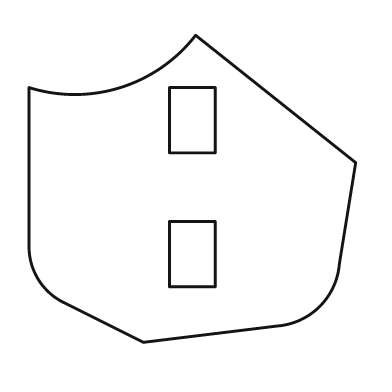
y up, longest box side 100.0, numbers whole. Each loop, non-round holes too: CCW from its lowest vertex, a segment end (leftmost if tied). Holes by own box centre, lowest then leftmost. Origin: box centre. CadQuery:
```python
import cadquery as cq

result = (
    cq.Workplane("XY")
    .moveTo(-15.0, -47.0)
    .lineTo(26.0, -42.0)
    .threePointArc((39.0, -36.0), (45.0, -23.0))
    .lineTo(50.0, 8.0)
    .lineTo(1.0, 47.0)
    .threePointArc((-22.0, 31.0), (-50.0, 31.0))
    .lineTo(-50.0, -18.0)
    .threePointArc((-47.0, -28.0), (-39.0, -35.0))
    .close()
    .moveTo(-7.0, -30.0)
    .lineTo(7.0, -30.0)
    .lineTo(7.0, -10.0)
    .lineTo(-7.0, -10.0)
    .close()
    .moveTo(-7.0, 11.0)
    .lineTo(7.0, 11.0)
    .lineTo(7.0, 31.0)
    .lineTo(-7.0, 31.0)
    .close()
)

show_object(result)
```